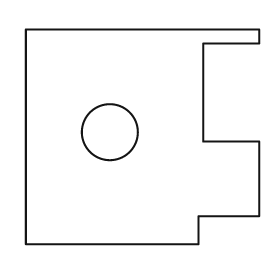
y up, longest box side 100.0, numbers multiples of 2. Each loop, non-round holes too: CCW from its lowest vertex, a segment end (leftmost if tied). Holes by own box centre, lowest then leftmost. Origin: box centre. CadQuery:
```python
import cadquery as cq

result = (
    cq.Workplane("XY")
    .moveTo(-50.0, -46.0)
    .lineTo(24.0, -46.0)
    .lineTo(24.0, -34.0)
    .lineTo(50.0, -34.0)
    .lineTo(50.0, -2.0)
    .lineTo(26.0, -2.0)
    .lineTo(26.0, 40.0)
    .lineTo(50.0, 40.0)
    .lineTo(50.0, 46.0)
    .lineTo(-50.0, 46.0)
    .close()
    .moveTo(-14.0, 2.0)
    .circle(12.0)
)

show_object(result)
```